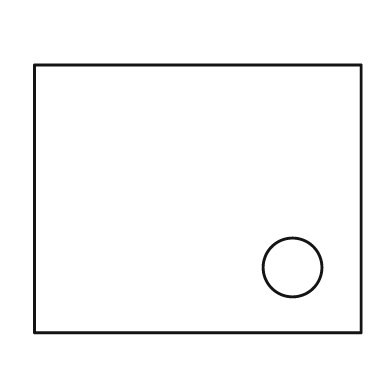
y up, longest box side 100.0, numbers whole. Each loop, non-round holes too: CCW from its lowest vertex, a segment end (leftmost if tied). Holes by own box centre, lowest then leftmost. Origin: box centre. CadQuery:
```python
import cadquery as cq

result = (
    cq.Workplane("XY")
    .moveTo(-50.0, -41.0)
    .lineTo(50.0, -41.0)
    .lineTo(50.0, 41.0)
    .lineTo(-50.0, 41.0)
    .close()
    .moveTo(29.0, -21.0)
    .circle(9.0)
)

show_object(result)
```